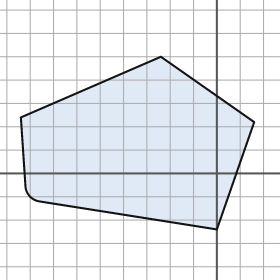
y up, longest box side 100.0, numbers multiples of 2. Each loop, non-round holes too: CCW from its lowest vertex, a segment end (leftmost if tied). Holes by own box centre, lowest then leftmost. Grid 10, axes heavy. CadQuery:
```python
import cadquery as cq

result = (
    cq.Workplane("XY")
    .moveTo(0.0, -24.0)
    .lineTo(16.0, 22.0)
    .lineTo(-24.0, 50.0)
    .lineTo(-84.0, 24.0)
    .lineTo(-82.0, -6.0)
    .threePointArc((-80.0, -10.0), (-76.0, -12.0))
    .close()
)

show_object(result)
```